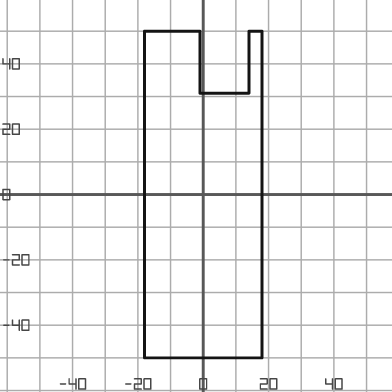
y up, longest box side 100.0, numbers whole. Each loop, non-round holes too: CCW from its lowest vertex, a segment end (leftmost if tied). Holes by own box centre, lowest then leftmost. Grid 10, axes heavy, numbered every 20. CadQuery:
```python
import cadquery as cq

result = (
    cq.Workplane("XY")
    .moveTo(-18.0, -50.0)
    .lineTo(18.0, -50.0)
    .lineTo(18.0, 50.0)
    .lineTo(14.0, 50.0)
    .lineTo(14.0, 31.0)
    .lineTo(-1.0, 31.0)
    .lineTo(-1.0, 50.0)
    .lineTo(-18.0, 50.0)
    .close()
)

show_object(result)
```